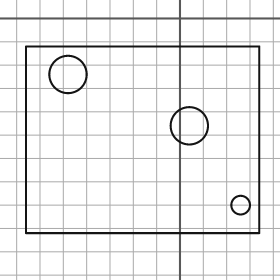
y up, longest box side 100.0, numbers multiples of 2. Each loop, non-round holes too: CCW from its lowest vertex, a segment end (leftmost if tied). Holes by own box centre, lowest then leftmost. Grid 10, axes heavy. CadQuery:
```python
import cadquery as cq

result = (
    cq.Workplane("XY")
    .moveTo(-66.0, -92.0)
    .lineTo(34.0, -92.0)
    .lineTo(34.0, -12.0)
    .lineTo(-66.0, -12.0)
    .close()
    .moveTo(26.0, -80.0)
    .circle(4.0)
    .moveTo(4.0, -46.0)
    .circle(8.0)
    .moveTo(-48.0, -24.0)
    .circle(8.0)
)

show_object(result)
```